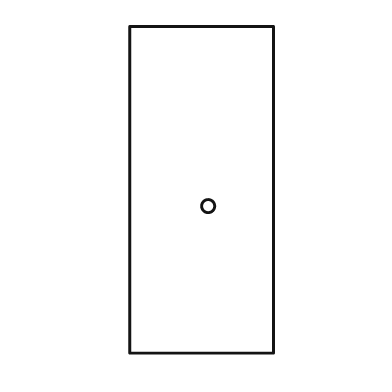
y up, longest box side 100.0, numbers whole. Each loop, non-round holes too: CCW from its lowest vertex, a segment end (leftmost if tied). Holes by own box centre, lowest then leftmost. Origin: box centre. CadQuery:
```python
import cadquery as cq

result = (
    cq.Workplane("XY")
    .moveTo(-22.0, -50.0)
    .lineTo(22.0, -50.0)
    .lineTo(22.0, 50.0)
    .lineTo(-22.0, 50.0)
    .close()
    .moveTo(2.0, -5.0)
    .circle(2.0)
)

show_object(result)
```